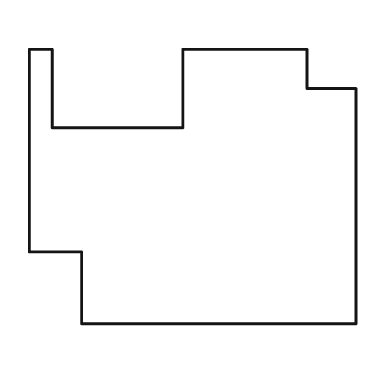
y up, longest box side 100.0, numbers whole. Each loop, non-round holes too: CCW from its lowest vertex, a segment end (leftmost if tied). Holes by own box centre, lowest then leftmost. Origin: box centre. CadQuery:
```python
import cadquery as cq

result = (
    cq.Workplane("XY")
    .moveTo(-34.0, -42.0)
    .lineTo(50.0, -42.0)
    .lineTo(50.0, 30.0)
    .lineTo(35.0, 30.0)
    .lineTo(35.0, 42.0)
    .lineTo(-3.0, 42.0)
    .lineTo(-3.0, 18.0)
    .lineTo(-43.0, 18.0)
    .lineTo(-43.0, 42.0)
    .lineTo(-50.0, 42.0)
    .lineTo(-50.0, -20.0)
    .lineTo(-34.0, -20.0)
    .close()
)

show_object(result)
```